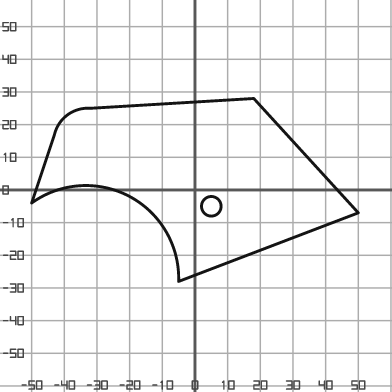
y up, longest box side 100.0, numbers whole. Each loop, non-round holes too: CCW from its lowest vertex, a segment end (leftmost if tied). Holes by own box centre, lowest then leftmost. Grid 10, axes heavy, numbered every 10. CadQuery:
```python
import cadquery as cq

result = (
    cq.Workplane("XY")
    .moveTo(-5.0, -28.0)
    .lineTo(50.0, -7.0)
    .lineTo(18.0, 28.0)
    .lineTo(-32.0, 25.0)
    .threePointArc((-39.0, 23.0), (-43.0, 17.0))
    .lineTo(-50.0, -4.0)
    .threePointArc((-20.0, -2.0), (-5.0, -28.0))
    .close()
    .moveTo(5.0, -5.0)
    .circle(3.0)
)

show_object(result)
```